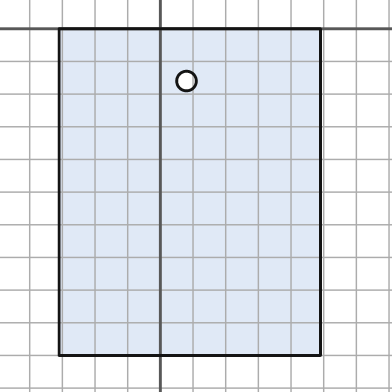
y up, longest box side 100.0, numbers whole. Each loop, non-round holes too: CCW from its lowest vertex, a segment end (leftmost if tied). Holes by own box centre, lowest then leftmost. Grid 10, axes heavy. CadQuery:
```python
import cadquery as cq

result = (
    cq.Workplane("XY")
    .moveTo(-31.0, -100.0)
    .lineTo(49.0, -100.0)
    .lineTo(49.0, 0.0)
    .lineTo(-31.0, 0.0)
    .close()
    .moveTo(8.0, -16.0)
    .circle(3.0)
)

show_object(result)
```